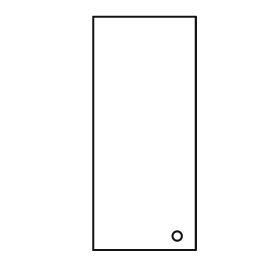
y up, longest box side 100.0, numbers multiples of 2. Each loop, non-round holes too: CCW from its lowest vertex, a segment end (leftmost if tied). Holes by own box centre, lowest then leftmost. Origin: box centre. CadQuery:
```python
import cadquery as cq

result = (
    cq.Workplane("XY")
    .moveTo(-22.0, -50.0)
    .lineTo(22.0, -50.0)
    .lineTo(22.0, 50.0)
    .lineTo(-22.0, 50.0)
    .close()
    .moveTo(14.0, -44.0)
    .circle(2.0)
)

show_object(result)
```